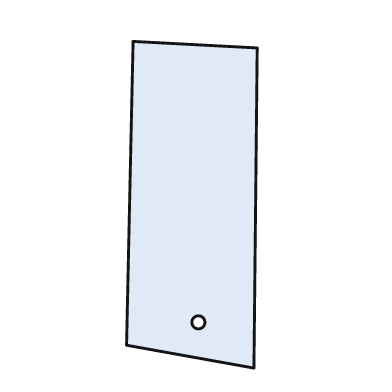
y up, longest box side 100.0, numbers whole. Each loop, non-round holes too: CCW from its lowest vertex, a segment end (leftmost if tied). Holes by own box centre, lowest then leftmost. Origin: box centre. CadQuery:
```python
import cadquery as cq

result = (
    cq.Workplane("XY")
    .moveTo(19.0, -50.0)
    .lineTo(20.0, 48.0)
    .lineTo(-18.0, 50.0)
    .lineTo(-20.0, -43.0)
    .close()
    .moveTo(2.0, -36.0)
    .circle(2.0)
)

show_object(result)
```